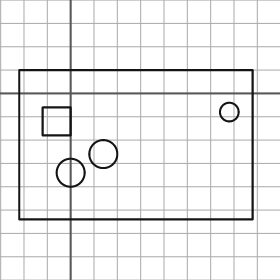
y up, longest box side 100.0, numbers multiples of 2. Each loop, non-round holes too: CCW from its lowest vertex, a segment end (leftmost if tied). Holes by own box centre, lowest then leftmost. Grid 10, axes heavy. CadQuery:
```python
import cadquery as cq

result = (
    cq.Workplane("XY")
    .moveTo(-22.0, -54.0)
    .lineTo(78.0, -54.0)
    .lineTo(78.0, 10.0)
    .lineTo(-22.0, 10.0)
    .close()
    .moveTo(0.0, -34.0)
    .circle(6.0)
    .moveTo(14.0, -26.0)
    .circle(6.0)
    .moveTo(-12.0, -18.0)
    .lineTo(0.0, -18.0)
    .lineTo(0.0, -6.0)
    .lineTo(-12.0, -6.0)
    .close()
    .moveTo(68.0, -8.0)
    .circle(4.0)
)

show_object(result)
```